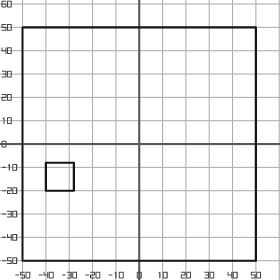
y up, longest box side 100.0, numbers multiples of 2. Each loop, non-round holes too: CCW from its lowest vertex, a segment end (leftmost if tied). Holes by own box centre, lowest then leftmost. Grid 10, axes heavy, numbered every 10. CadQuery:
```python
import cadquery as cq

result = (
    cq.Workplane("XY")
    .moveTo(-50.0, -50.0)
    .lineTo(50.0, -50.0)
    .lineTo(50.0, 50.0)
    .lineTo(-50.0, 50.0)
    .close()
    .moveTo(-40.0, -20.0)
    .lineTo(-28.0, -20.0)
    .lineTo(-28.0, -8.0)
    .lineTo(-40.0, -8.0)
    .close()
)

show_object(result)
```